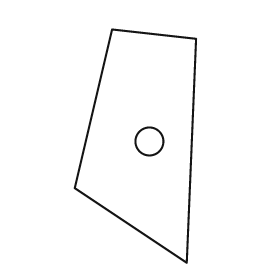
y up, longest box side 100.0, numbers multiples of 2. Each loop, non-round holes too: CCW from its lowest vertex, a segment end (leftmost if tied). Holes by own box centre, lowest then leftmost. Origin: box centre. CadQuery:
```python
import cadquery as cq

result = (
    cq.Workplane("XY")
    .moveTo(22.0, -50.0)
    .lineTo(26.0, 46.0)
    .lineTo(-10.0, 50.0)
    .lineTo(-26.0, -18.0)
    .close()
    .moveTo(6.0, 2.0)
    .circle(6.0)
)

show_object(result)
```